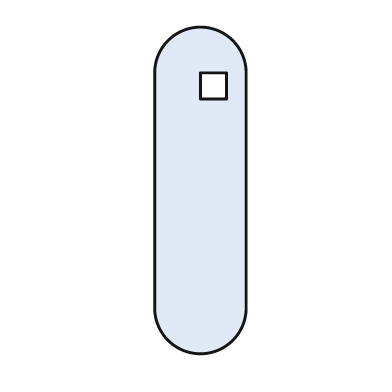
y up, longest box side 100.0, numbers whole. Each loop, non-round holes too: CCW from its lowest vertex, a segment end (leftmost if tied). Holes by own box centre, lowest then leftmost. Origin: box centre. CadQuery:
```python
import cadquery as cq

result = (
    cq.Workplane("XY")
    .moveTo(-14.0, -36.0)
    .threePointArc((0.0, -50.0), (14.0, -36.0))
    .lineTo(14.0, 36.0)
    .threePointArc((0.0, 50.0), (-14.0, 36.0))
    .close()
    .moveTo(0.0, 28.0)
    .lineTo(8.0, 28.0)
    .lineTo(8.0, 36.0)
    .lineTo(0.0, 36.0)
    .close()
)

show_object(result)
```